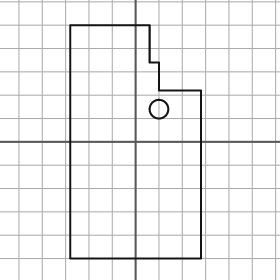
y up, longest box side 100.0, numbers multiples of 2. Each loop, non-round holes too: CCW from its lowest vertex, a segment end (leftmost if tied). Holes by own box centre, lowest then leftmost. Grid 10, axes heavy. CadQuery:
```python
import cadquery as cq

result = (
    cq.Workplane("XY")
    .moveTo(-28.0, -50.0)
    .lineTo(28.0, -50.0)
    .lineTo(28.0, 22.0)
    .lineTo(10.0, 22.0)
    .lineTo(10.0, 34.0)
    .lineTo(6.0, 34.0)
    .lineTo(6.0, 50.0)
    .lineTo(-28.0, 50.0)
    .close()
    .moveTo(10.0, 14.0)
    .circle(4.0)
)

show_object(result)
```